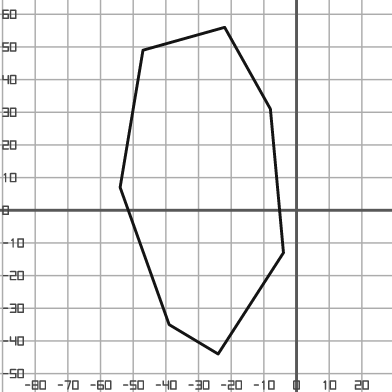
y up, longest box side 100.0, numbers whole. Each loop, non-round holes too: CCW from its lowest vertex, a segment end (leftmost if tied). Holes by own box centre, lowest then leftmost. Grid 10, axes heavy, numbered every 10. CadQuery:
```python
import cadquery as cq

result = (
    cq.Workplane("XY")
    .moveTo(-24.0, -44.0)
    .lineTo(-4.0, -13.0)
    .lineTo(-8.0, 31.0)
    .lineTo(-22.0, 56.0)
    .lineTo(-47.0, 49.0)
    .lineTo(-54.0, 7.0)
    .lineTo(-39.0, -35.0)
    .close()
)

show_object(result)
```